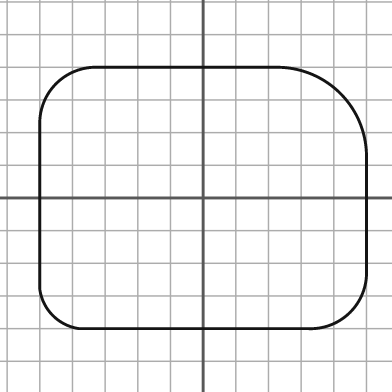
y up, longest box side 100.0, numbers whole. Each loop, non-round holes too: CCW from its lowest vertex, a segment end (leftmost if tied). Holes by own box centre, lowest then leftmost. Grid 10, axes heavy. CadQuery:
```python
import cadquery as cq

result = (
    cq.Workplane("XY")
    .moveTo(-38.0, -40.0)
    .lineTo(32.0, -40.0)
    .threePointArc((45.0, -35.0), (50.0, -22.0))
    .lineTo(50.0, 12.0)
    .threePointArc((42.0, 32.0), (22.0, 40.0))
    .lineTo(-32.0, 40.0)
    .threePointArc((-45.0, 35.0), (-50.0, 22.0))
    .lineTo(-50.0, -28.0)
    .threePointArc((-46.0, -36.0), (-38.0, -40.0))
    .close()
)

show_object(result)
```